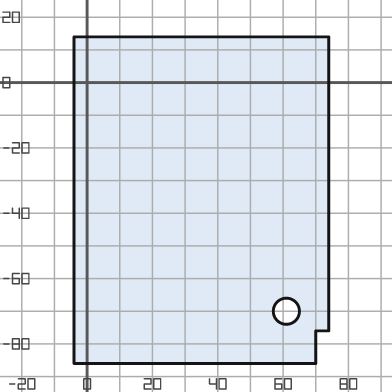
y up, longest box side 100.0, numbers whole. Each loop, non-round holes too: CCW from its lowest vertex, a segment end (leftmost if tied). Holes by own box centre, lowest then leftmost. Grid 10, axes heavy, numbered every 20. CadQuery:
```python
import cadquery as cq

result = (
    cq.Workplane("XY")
    .moveTo(-4.0, -86.0)
    .lineTo(70.0, -86.0)
    .lineTo(70.0, -76.0)
    .lineTo(74.0, -76.0)
    .lineTo(74.0, 14.0)
    .lineTo(-4.0, 14.0)
    .close()
    .moveTo(61.0, -70.0)
    .circle(4.0)
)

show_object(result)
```